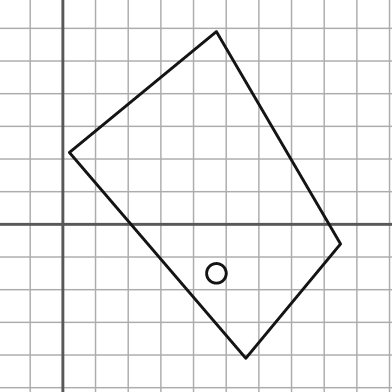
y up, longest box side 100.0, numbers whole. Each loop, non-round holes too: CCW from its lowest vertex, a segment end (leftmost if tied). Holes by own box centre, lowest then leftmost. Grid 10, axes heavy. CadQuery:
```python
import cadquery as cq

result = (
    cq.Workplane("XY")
    .moveTo(56.0, -41.0)
    .lineTo(85.0, -6.0)
    .lineTo(47.0, 59.0)
    .lineTo(2.0, 22.0)
    .close()
    .moveTo(47.0, -15.0)
    .circle(3.0)
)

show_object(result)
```